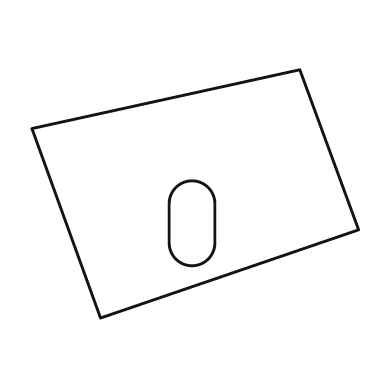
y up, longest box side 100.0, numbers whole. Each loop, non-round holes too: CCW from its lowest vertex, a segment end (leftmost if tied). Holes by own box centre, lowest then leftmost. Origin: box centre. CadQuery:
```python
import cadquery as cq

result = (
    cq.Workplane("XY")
    .moveTo(-29.0, -38.0)
    .lineTo(50.0, -11.0)
    .lineTo(32.0, 38.0)
    .lineTo(-50.0, 20.0)
    .close()
    .moveTo(-8.0, -15.0)
    .threePointArc((-1.0, -22.0), (6.0, -15.0))
    .lineTo(6.0, -3.0)
    .threePointArc((-1.0, 4.0), (-8.0, -3.0))
    .close()
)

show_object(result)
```